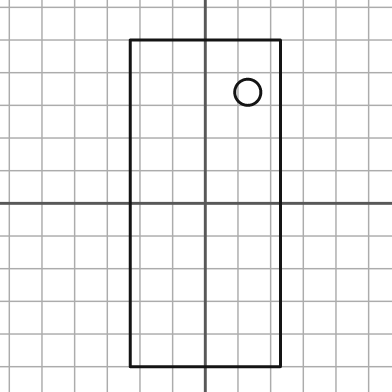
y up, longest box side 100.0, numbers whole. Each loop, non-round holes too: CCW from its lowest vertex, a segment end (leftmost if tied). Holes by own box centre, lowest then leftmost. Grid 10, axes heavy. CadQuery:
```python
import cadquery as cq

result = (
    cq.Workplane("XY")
    .moveTo(-23.0, -50.0)
    .lineTo(23.0, -50.0)
    .lineTo(23.0, 50.0)
    .lineTo(-23.0, 50.0)
    .close()
    .moveTo(13.0, 34.0)
    .circle(4.0)
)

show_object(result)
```